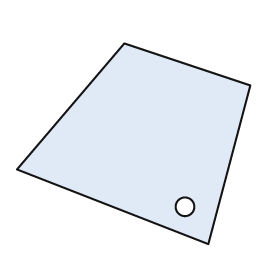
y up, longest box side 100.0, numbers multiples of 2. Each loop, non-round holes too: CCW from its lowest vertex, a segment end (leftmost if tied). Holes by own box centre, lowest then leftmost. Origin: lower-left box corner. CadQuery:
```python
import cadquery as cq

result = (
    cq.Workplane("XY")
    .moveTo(82.0, 0.0)
    .lineTo(100.0, 68.0)
    .lineTo(46.0, 86.0)
    .lineTo(0.0, 32.0)
    .close()
    .moveTo(72.0, 16.0)
    .circle(4.0)
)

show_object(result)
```